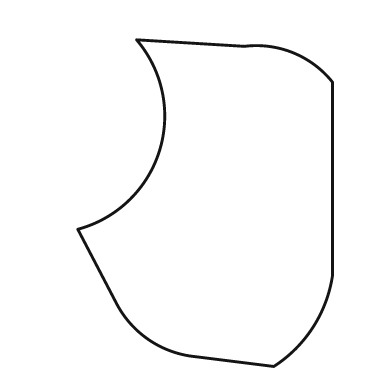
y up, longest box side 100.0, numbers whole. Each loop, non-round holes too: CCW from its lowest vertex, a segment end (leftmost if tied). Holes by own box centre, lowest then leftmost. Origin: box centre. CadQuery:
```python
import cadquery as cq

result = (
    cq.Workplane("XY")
    .moveTo(21.0, -50.0)
    .threePointArc((33.0, -38.0), (39.0, -22.0))
    .lineTo(39.0, 37.0)
    .threePointArc((27.0, 46.0), (12.0, 48.0))
    .lineTo(-21.0, 50.0)
    .threePointArc((-14.0, 16.0), (-39.0, -8.0))
    .lineTo(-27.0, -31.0)
    .threePointArc((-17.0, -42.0), (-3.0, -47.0))
    .close()
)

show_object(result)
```